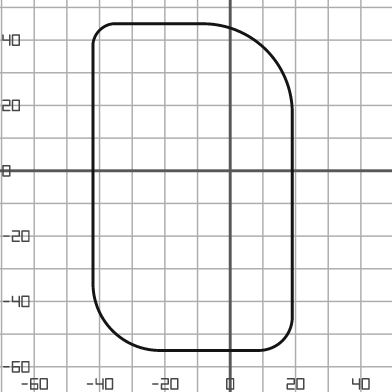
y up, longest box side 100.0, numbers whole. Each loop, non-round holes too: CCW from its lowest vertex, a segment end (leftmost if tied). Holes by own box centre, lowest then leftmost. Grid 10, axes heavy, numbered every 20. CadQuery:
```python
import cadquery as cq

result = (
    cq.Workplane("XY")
    .moveTo(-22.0, -55.0)
    .lineTo(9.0, -55.0)
    .threePointArc((16.0, -52.0), (19.0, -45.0))
    .lineTo(19.0, 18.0)
    .threePointArc((11.0, 37.0), (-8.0, 45.0))
    .lineTo(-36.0, 45.0)
    .threePointArc((-40.0, 43.0), (-42.0, 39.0))
    .lineTo(-42.0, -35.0)
    .threePointArc((-36.0, -49.0), (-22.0, -55.0))
    .close()
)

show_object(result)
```